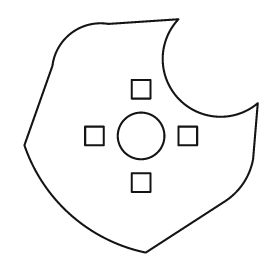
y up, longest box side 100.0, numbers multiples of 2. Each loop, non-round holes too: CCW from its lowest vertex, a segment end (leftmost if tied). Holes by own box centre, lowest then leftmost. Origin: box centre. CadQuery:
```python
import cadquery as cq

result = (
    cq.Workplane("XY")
    .moveTo(2.0, -50.0)
    .lineTo(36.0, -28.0)
    .threePointArc((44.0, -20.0), (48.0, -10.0))
    .lineTo(50.0, 14.0)
    .threePointArc((16.0, 16.0), (16.0, 50.0))
    .lineTo(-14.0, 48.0)
    .threePointArc((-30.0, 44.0), (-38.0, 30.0))
    .lineTo(-50.0, -4.0)
    .threePointArc((-30.0, -34.0), (2.0, -50.0))
    .close()
    .moveTo(-4.0, -24.0)
    .lineTo(4.0, -24.0)
    .lineTo(4.0, -16.0)
    .lineTo(-4.0, -16.0)
    .close()
    .moveTo(-24.0, -4.0)
    .lineTo(-16.0, -4.0)
    .lineTo(-16.0, 4.0)
    .lineTo(-24.0, 4.0)
    .close()
    .moveTo(0.0, 0.0)
    .circle(10.0)
    .moveTo(16.0, -4.0)
    .lineTo(24.0, -4.0)
    .lineTo(24.0, 4.0)
    .lineTo(16.0, 4.0)
    .close()
    .moveTo(-4.0, 16.0)
    .lineTo(4.0, 16.0)
    .lineTo(4.0, 24.0)
    .lineTo(-4.0, 24.0)
    .close()
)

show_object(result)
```